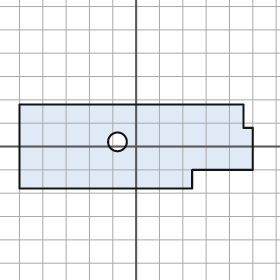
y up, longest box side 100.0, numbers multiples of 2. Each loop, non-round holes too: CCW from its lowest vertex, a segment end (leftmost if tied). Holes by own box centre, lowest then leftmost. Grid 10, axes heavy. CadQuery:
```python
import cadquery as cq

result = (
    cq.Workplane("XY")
    .moveTo(-50.0, -18.0)
    .lineTo(24.0, -18.0)
    .lineTo(24.0, -10.0)
    .lineTo(50.0, -10.0)
    .lineTo(50.0, 8.0)
    .lineTo(46.0, 8.0)
    .lineTo(46.0, 18.0)
    .lineTo(-50.0, 18.0)
    .close()
    .moveTo(-8.0, 2.0)
    .circle(4.0)
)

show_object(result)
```